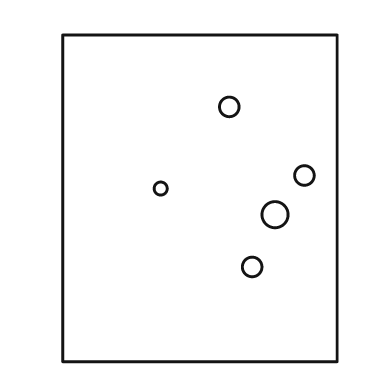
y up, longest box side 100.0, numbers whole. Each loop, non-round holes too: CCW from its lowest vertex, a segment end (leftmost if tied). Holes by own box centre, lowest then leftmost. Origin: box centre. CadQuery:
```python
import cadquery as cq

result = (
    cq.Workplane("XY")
    .moveTo(-42.0, -50.0)
    .lineTo(42.0, -50.0)
    .lineTo(42.0, 50.0)
    .lineTo(-42.0, 50.0)
    .close()
    .moveTo(16.0, -21.0)
    .circle(3.0)
    .moveTo(23.0, -5.0)
    .circle(4.0)
    .moveTo(-12.0, 3.0)
    .circle(2.0)
    .moveTo(32.0, 7.0)
    .circle(3.0)
    .moveTo(9.0, 28.0)
    .circle(3.0)
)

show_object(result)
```